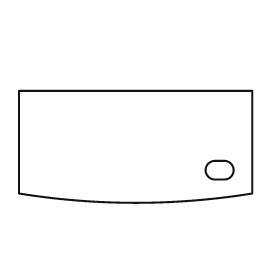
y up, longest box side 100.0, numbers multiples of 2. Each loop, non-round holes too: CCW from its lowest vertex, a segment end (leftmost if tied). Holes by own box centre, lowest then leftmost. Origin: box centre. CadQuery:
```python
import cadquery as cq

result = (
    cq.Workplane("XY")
    .moveTo(-50.0, -20.0)
    .threePointArc((0.0, -24.0), (50.0, -20.0))
    .lineTo(50.0, 24.0)
    .lineTo(-50.0, 24.0)
    .close()
    .moveTo(34.0, -14.0)
    .lineTo(38.0, -14.0)
    .threePointArc((42.0, -10.0), (38.0, -6.0))
    .lineTo(34.0, -6.0)
    .threePointArc((30.0, -10.0), (34.0, -14.0))
    .close()
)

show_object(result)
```